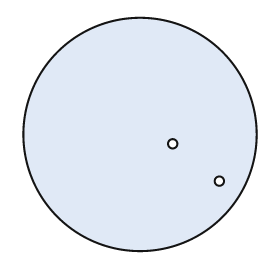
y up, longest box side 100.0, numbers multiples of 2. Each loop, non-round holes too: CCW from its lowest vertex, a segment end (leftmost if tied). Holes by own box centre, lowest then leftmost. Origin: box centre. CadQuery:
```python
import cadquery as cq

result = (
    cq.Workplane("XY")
    .moveTo(0.0, 0.0)
    .circle(50.0)
    .moveTo(34.0, -20.0)
    .circle(2.0)
    .moveTo(14.0, -4.0)
    .circle(2.0)
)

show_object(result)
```